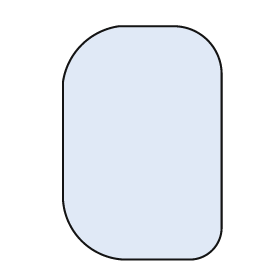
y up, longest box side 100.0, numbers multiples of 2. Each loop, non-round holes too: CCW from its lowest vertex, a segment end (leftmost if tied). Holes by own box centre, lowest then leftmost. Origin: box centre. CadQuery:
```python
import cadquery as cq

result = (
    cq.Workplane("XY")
    .moveTo(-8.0, -50.0)
    .lineTo(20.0, -50.0)
    .threePointArc((30.0, -46.0), (34.0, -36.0))
    .lineTo(34.0, 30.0)
    .threePointArc((28.0, 44.0), (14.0, 50.0))
    .lineTo(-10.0, 50.0)
    .threePointArc((-26.0, 42.0), (-34.0, 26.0))
    .lineTo(-34.0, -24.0)
    .threePointArc((-26.0, -42.0), (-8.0, -50.0))
    .close()
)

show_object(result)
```